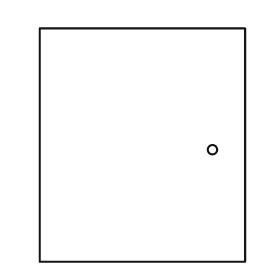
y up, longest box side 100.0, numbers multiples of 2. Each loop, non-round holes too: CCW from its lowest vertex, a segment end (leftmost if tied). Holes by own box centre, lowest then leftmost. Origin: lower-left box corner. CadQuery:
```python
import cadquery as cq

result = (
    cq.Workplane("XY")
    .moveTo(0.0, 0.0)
    .lineTo(88.0, 0.0)
    .lineTo(88.0, 100.0)
    .lineTo(0.0, 100.0)
    .close()
    .moveTo(74.0, 48.0)
    .circle(2.0)
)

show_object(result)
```